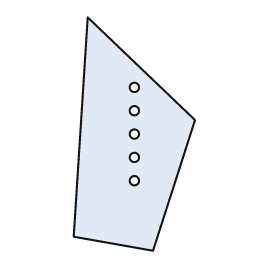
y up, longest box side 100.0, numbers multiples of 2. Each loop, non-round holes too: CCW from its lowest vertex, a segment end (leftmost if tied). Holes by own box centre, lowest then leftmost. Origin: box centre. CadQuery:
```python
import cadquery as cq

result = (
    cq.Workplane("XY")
    .moveTo(8.0, -50.0)
    .lineTo(26.0, 6.0)
    .lineTo(-20.0, 50.0)
    .lineTo(-26.0, -44.0)
    .close()
    .moveTo(0.0, -20.0)
    .circle(2.0)
    .moveTo(0.0, -10.0)
    .circle(2.0)
    .moveTo(0.0, 0.0)
    .circle(2.0)
    .moveTo(0.0, 10.0)
    .circle(2.0)
    .moveTo(0.0, 20.0)
    .circle(2.0)
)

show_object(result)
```